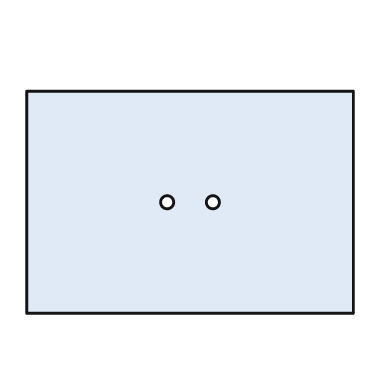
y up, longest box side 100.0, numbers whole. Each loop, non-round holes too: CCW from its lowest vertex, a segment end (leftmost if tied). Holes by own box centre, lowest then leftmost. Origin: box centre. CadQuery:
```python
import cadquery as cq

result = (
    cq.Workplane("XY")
    .moveTo(-50.0, -34.0)
    .lineTo(50.0, -34.0)
    .lineTo(50.0, 34.0)
    .lineTo(-50.0, 34.0)
    .close()
    .moveTo(-7.0, 0.0)
    .circle(2.0)
    .moveTo(7.0, 0.0)
    .circle(2.0)
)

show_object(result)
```